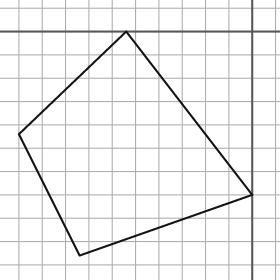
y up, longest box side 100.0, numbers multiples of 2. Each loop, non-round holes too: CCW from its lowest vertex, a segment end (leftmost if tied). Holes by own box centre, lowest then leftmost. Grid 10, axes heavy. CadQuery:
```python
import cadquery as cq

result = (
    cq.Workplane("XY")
    .moveTo(-74.0, -96.0)
    .lineTo(0.0, -70.0)
    .lineTo(-54.0, 0.0)
    .lineTo(-100.0, -44.0)
    .close()
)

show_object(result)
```